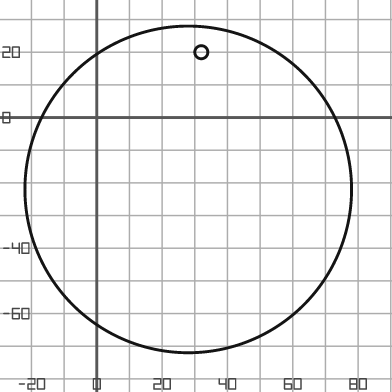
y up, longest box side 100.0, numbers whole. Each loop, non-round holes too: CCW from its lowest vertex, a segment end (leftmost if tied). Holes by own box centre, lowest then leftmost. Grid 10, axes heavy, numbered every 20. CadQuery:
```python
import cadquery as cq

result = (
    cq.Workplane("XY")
    .moveTo(28.0, -22.0)
    .circle(50.0)
    .moveTo(32.0, 20.0)
    .circle(2.0)
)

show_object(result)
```